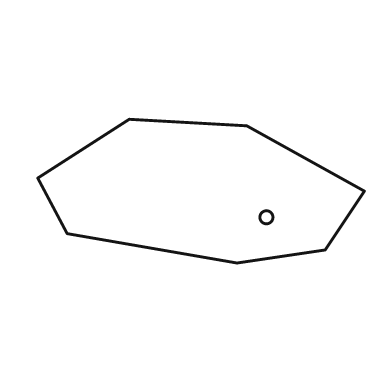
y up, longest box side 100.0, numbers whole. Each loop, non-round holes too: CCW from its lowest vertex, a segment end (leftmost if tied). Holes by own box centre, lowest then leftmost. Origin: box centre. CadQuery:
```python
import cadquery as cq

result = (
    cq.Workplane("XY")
    .moveTo(11.0, -22.0)
    .lineTo(38.0, -18.0)
    .lineTo(50.0, 0.0)
    .lineTo(14.0, 20.0)
    .lineTo(-22.0, 22.0)
    .lineTo(-50.0, 4.0)
    .lineTo(-41.0, -13.0)
    .close()
    .moveTo(20.0, -8.0)
    .circle(2.0)
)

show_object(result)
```